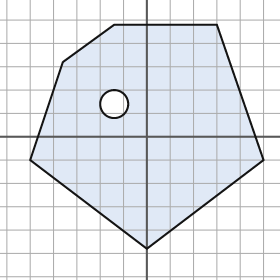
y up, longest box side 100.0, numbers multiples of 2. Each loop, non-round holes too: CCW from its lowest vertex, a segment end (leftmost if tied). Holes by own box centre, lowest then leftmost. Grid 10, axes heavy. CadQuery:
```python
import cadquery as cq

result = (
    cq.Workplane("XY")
    .moveTo(0.0, -48.0)
    .lineTo(50.0, -10.0)
    .lineTo(30.0, 48.0)
    .lineTo(-14.0, 48.0)
    .lineTo(-36.0, 32.0)
    .lineTo(-50.0, -10.0)
    .close()
    .moveTo(-14.0, 14.0)
    .circle(6.0)
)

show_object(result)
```